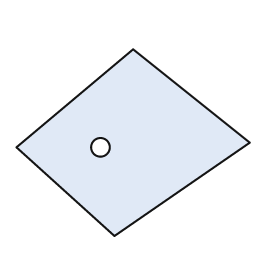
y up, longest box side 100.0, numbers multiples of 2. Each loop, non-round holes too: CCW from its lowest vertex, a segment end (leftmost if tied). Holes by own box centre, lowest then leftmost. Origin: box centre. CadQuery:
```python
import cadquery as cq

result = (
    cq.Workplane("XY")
    .moveTo(-8.0, -40.0)
    .lineTo(50.0, 0.0)
    .lineTo(0.0, 40.0)
    .lineTo(-50.0, -2.0)
    .close()
    .moveTo(-14.0, -2.0)
    .circle(4.0)
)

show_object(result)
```